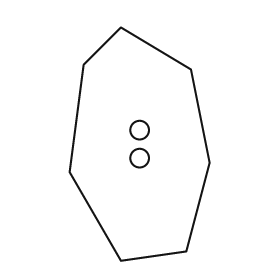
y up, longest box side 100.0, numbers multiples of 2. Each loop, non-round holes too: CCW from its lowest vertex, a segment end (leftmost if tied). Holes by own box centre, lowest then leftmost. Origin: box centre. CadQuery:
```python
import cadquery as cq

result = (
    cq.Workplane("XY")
    .moveTo(-8.0, -50.0)
    .lineTo(20.0, -46.0)
    .lineTo(30.0, -8.0)
    .lineTo(22.0, 32.0)
    .lineTo(-8.0, 50.0)
    .lineTo(-24.0, 34.0)
    .lineTo(-30.0, -12.0)
    .close()
    .moveTo(0.0, -6.0)
    .circle(4.0)
    .moveTo(0.0, 6.0)
    .circle(4.0)
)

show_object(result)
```